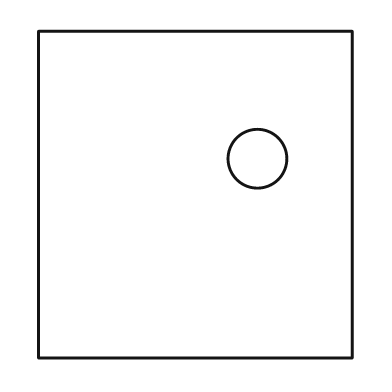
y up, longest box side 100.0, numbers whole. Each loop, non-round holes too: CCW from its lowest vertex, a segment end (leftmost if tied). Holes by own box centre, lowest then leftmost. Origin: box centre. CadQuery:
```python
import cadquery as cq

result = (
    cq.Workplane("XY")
    .moveTo(-48.0, -50.0)
    .lineTo(48.0, -50.0)
    .lineTo(48.0, 50.0)
    .lineTo(-48.0, 50.0)
    .close()
    .moveTo(19.0, 11.0)
    .circle(9.0)
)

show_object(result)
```